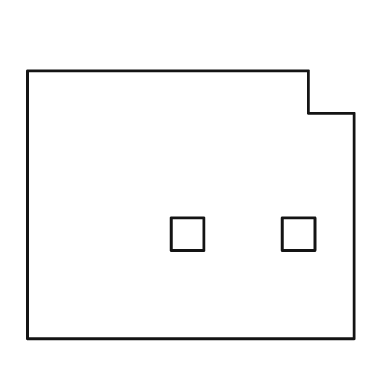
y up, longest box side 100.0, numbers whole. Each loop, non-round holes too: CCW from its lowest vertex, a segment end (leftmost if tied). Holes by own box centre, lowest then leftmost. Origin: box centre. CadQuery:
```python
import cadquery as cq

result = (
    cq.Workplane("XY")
    .moveTo(-50.0, -41.0)
    .lineTo(50.0, -41.0)
    .lineTo(50.0, 28.0)
    .lineTo(36.0, 28.0)
    .lineTo(36.0, 41.0)
    .lineTo(-50.0, 41.0)
    .close()
    .moveTo(-6.0, -14.0)
    .lineTo(4.0, -14.0)
    .lineTo(4.0, -4.0)
    .lineTo(-6.0, -4.0)
    .close()
    .moveTo(28.0, -14.0)
    .lineTo(38.0, -14.0)
    .lineTo(38.0, -4.0)
    .lineTo(28.0, -4.0)
    .close()
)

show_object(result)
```